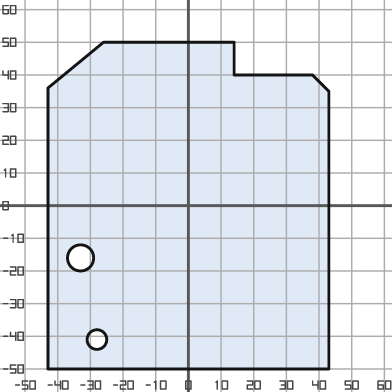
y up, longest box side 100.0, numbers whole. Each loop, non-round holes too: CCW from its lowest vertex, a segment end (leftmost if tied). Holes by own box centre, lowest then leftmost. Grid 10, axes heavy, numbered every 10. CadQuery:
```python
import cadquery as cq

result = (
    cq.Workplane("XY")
    .moveTo(-43.0, -50.0)
    .lineTo(43.0, -50.0)
    .lineTo(43.0, 35.0)
    .lineTo(38.0, 40.0)
    .lineTo(14.0, 40.0)
    .lineTo(14.0, 50.0)
    .lineTo(-26.0, 50.0)
    .lineTo(-43.0, 36.0)
    .close()
    .moveTo(-28.0, -41.0)
    .circle(3.0)
    .moveTo(-33.0, -16.0)
    .circle(4.0)
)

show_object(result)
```